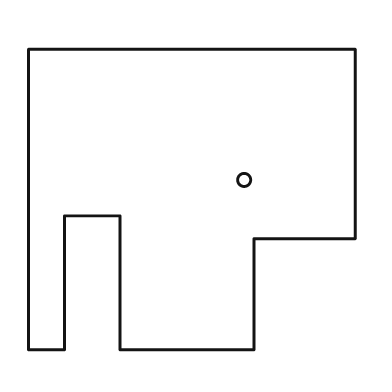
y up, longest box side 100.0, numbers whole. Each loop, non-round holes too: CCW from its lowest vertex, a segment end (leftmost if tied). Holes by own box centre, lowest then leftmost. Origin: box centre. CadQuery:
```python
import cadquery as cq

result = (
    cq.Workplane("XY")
    .moveTo(-50.0, -46.0)
    .lineTo(-39.0, -46.0)
    .lineTo(-39.0, -5.0)
    .lineTo(-22.0, -5.0)
    .lineTo(-22.0, -46.0)
    .lineTo(19.0, -46.0)
    .lineTo(19.0, -12.0)
    .lineTo(50.0, -12.0)
    .lineTo(50.0, 46.0)
    .lineTo(-50.0, 46.0)
    .close()
    .moveTo(16.0, 6.0)
    .circle(2.0)
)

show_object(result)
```